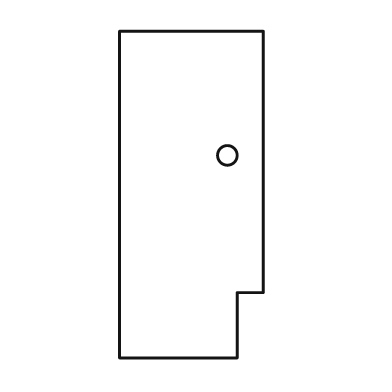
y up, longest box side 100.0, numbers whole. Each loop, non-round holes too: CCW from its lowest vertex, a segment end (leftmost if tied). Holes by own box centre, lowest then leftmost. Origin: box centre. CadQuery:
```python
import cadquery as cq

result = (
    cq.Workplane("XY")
    .moveTo(-22.0, -50.0)
    .lineTo(14.0, -50.0)
    .lineTo(14.0, -30.0)
    .lineTo(22.0, -30.0)
    .lineTo(22.0, 50.0)
    .lineTo(-22.0, 50.0)
    .close()
    .moveTo(11.0, 12.0)
    .circle(3.0)
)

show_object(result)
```